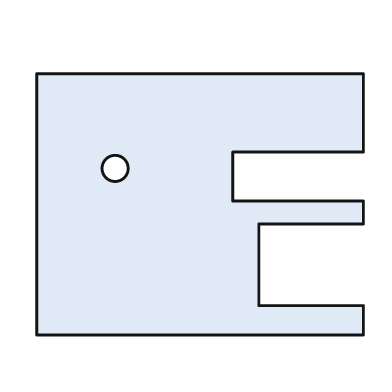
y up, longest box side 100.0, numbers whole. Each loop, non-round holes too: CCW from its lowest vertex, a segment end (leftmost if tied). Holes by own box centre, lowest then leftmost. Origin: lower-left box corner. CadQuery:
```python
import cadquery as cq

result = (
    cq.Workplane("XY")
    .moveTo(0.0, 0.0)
    .lineTo(100.0, 0.0)
    .lineTo(100.0, 9.0)
    .lineTo(68.0, 9.0)
    .lineTo(68.0, 34.0)
    .lineTo(100.0, 34.0)
    .lineTo(100.0, 41.0)
    .lineTo(60.0, 41.0)
    .lineTo(60.0, 56.0)
    .lineTo(100.0, 56.0)
    .lineTo(100.0, 80.0)
    .lineTo(0.0, 80.0)
    .close()
    .moveTo(24.0, 51.0)
    .circle(4.0)
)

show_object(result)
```